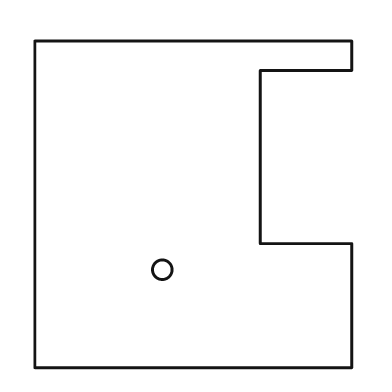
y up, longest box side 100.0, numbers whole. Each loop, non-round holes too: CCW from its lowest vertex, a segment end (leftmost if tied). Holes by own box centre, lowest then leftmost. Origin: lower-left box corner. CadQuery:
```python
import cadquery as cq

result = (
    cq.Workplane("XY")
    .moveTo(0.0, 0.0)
    .lineTo(97.0, 0.0)
    .lineTo(97.0, 38.0)
    .lineTo(69.0, 38.0)
    .lineTo(69.0, 91.0)
    .lineTo(97.0, 91.0)
    .lineTo(97.0, 100.0)
    .lineTo(0.0, 100.0)
    .close()
    .moveTo(39.0, 30.0)
    .circle(3.0)
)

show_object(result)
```